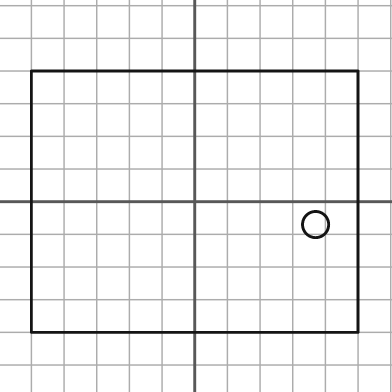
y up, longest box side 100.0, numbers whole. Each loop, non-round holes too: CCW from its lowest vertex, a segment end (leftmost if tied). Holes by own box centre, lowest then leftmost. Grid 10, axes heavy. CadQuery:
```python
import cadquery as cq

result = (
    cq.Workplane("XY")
    .moveTo(-50.0, -40.0)
    .lineTo(50.0, -40.0)
    .lineTo(50.0, 40.0)
    .lineTo(-50.0, 40.0)
    .close()
    .moveTo(37.0, -7.0)
    .circle(4.0)
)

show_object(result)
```